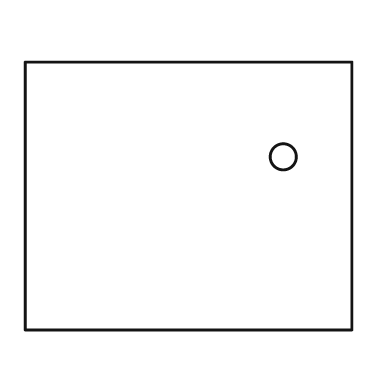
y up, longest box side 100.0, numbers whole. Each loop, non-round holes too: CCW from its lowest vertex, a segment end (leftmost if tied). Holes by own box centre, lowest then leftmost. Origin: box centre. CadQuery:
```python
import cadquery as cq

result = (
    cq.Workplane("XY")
    .moveTo(-50.0, -41.0)
    .lineTo(50.0, -41.0)
    .lineTo(50.0, 41.0)
    .lineTo(-50.0, 41.0)
    .close()
    .moveTo(29.0, 12.0)
    .circle(4.0)
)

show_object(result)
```